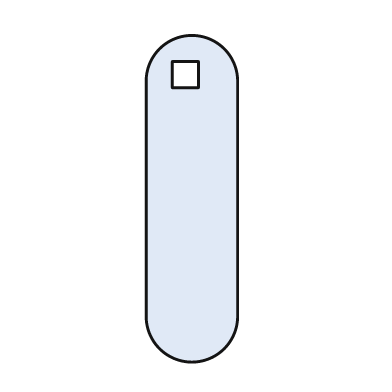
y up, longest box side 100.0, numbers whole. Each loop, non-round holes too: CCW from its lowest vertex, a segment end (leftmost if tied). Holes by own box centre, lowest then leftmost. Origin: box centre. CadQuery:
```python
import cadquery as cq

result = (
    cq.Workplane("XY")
    .moveTo(-14.0, -36.0)
    .threePointArc((0.0, -50.0), (14.0, -36.0))
    .lineTo(14.0, 36.0)
    .threePointArc((0.0, 50.0), (-14.0, 36.0))
    .close()
    .moveTo(-6.0, 34.0)
    .lineTo(2.0, 34.0)
    .lineTo(2.0, 42.0)
    .lineTo(-6.0, 42.0)
    .close()
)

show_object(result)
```